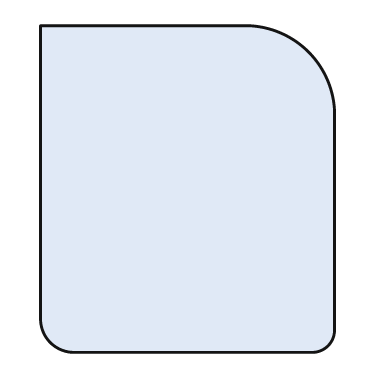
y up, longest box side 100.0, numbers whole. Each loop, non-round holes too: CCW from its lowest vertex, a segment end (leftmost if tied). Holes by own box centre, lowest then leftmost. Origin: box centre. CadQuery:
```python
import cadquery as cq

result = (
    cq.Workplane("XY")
    .moveTo(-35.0, -50.0)
    .lineTo(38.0, -50.0)
    .threePointArc((43.0, -48.0), (45.0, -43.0))
    .lineTo(45.0, 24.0)
    .threePointArc((37.0, 42.0), (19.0, 50.0))
    .lineTo(-45.0, 50.0)
    .lineTo(-45.0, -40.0)
    .threePointArc((-42.0, -47.0), (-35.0, -50.0))
    .close()
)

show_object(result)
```